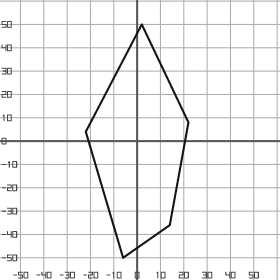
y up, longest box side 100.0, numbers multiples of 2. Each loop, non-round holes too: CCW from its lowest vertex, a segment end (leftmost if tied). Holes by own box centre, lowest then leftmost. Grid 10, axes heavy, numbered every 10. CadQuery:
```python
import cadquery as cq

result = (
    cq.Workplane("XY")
    .moveTo(-6.0, -50.0)
    .lineTo(14.0, -36.0)
    .lineTo(22.0, 8.0)
    .lineTo(2.0, 50.0)
    .lineTo(-22.0, 4.0)
    .close()
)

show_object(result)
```